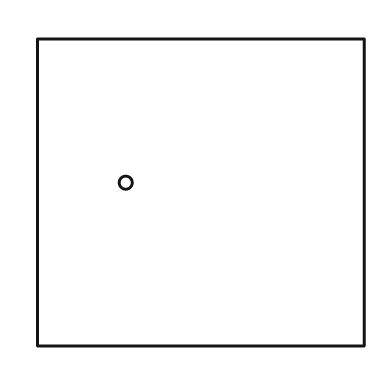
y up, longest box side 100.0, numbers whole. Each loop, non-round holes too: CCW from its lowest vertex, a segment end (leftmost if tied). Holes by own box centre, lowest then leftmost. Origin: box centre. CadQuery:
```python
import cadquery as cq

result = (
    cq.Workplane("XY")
    .moveTo(-50.0, -47.0)
    .lineTo(50.0, -47.0)
    .lineTo(50.0, 47.0)
    .lineTo(-50.0, 47.0)
    .close()
    .moveTo(-23.0, 3.0)
    .circle(2.0)
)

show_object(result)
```